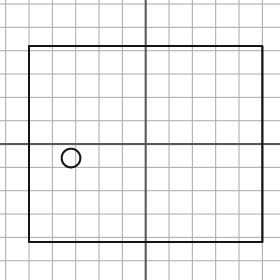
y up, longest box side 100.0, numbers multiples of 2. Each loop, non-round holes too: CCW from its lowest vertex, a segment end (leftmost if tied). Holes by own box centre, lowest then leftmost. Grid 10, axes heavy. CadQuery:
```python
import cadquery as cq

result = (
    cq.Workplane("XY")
    .moveTo(-50.0, -42.0)
    .lineTo(50.0, -42.0)
    .lineTo(50.0, 42.0)
    .lineTo(-50.0, 42.0)
    .close()
    .moveTo(-32.0, -6.0)
    .circle(4.0)
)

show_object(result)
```